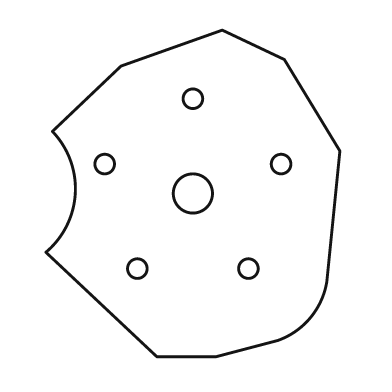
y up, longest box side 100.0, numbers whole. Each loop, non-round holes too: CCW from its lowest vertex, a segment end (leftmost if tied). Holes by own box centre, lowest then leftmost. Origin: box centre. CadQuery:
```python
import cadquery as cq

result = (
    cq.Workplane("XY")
    .moveTo(-11.0, -50.0)
    .lineTo(7.0, -50.0)
    .lineTo(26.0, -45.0)
    .threePointArc((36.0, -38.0), (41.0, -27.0))
    .lineTo(45.0, 13.0)
    .lineTo(28.0, 41.0)
    .lineTo(9.0, 50.0)
    .lineTo(-22.0, 39.0)
    .lineTo(-43.0, 19.0)
    .threePointArc((-36.0, 0.0), (-45.0, -18.0))
    .close()
    .moveTo(-17.0, -23.0)
    .circle(3.0)
    .moveTo(17.0, -23.0)
    .circle(3.0)
    .moveTo(0.0, 0.0)
    .circle(6.0)
    .moveTo(-27.0, 9.0)
    .circle(3.0)
    .moveTo(27.0, 9.0)
    .circle(3.0)
    .moveTo(0.0, 29.0)
    .circle(3.0)
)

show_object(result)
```